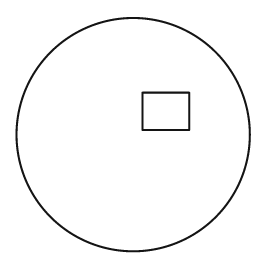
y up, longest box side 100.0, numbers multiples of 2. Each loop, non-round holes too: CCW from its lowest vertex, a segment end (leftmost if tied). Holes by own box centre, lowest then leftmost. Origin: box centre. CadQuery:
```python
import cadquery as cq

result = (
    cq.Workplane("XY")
    .moveTo(0.0, 0.0)
    .circle(50.0)
    .moveTo(4.0, 2.0)
    .lineTo(24.0, 2.0)
    .lineTo(24.0, 18.0)
    .lineTo(4.0, 18.0)
    .close()
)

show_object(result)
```